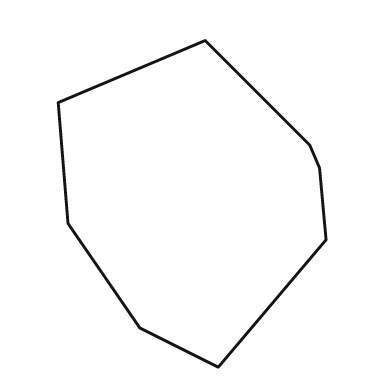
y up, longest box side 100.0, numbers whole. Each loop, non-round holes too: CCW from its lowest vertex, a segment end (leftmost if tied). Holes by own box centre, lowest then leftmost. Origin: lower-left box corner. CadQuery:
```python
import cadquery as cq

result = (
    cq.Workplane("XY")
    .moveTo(49.0, 0.0)
    .lineTo(82.0, 39.0)
    .lineTo(80.0, 61.0)
    .lineTo(77.0, 68.0)
    .lineTo(45.0, 100.0)
    .lineTo(0.0, 81.0)
    .lineTo(3.0, 44.0)
    .lineTo(25.0, 12.0)
    .close()
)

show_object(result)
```